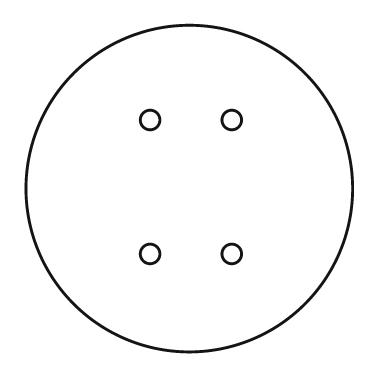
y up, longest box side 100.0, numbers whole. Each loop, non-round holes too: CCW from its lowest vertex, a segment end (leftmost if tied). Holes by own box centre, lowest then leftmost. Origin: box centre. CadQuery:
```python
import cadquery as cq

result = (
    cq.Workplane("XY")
    .moveTo(0.0, 0.0)
    .circle(50.0)
    .moveTo(-12.0, -20.0)
    .circle(3.0)
    .moveTo(13.0, -20.0)
    .circle(3.0)
    .moveTo(-12.0, 21.0)
    .circle(3.0)
    .moveTo(13.0, 21.0)
    .circle(3.0)
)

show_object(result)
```